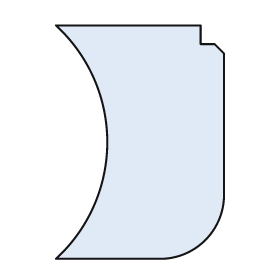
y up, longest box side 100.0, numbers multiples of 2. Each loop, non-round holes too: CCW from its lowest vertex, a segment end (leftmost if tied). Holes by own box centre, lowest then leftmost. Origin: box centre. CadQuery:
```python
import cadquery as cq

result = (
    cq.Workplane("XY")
    .moveTo(-36.0, -50.0)
    .lineTo(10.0, -50.0)
    .threePointArc((28.0, -42.0), (36.0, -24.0))
    .lineTo(36.0, 38.0)
    .lineTo(32.0, 42.0)
    .lineTo(26.0, 42.0)
    .lineTo(26.0, 50.0)
    .lineTo(-36.0, 50.0)
    .threePointArc((-14.0, 0.0), (-36.0, -50.0))
    .close()
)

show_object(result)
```